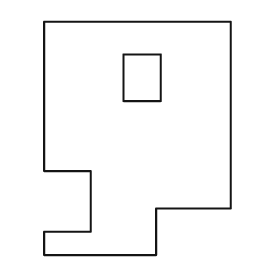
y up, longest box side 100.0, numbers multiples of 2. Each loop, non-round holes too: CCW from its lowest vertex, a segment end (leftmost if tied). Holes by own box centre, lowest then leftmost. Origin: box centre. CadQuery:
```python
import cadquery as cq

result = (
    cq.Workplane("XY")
    .moveTo(-40.0, -50.0)
    .lineTo(8.0, -50.0)
    .lineTo(8.0, -30.0)
    .lineTo(40.0, -30.0)
    .lineTo(40.0, 50.0)
    .lineTo(-40.0, 50.0)
    .lineTo(-40.0, -14.0)
    .lineTo(-20.0, -14.0)
    .lineTo(-20.0, -40.0)
    .lineTo(-40.0, -40.0)
    .close()
    .moveTo(-6.0, 16.0)
    .lineTo(10.0, 16.0)
    .lineTo(10.0, 36.0)
    .lineTo(-6.0, 36.0)
    .close()
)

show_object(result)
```